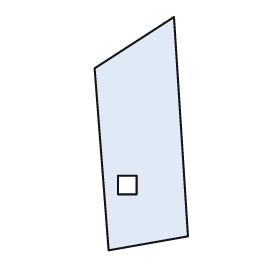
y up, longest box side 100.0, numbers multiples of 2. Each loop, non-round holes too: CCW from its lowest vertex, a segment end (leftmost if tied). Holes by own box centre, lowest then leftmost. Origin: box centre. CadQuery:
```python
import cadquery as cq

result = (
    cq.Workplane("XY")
    .moveTo(-14.0, -50.0)
    .lineTo(20.0, -44.0)
    .lineTo(14.0, 50.0)
    .lineTo(-20.0, 28.0)
    .close()
    .moveTo(-10.0, -26.0)
    .lineTo(-2.0, -26.0)
    .lineTo(-2.0, -18.0)
    .lineTo(-10.0, -18.0)
    .close()
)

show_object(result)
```